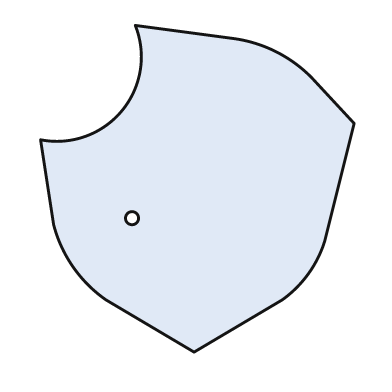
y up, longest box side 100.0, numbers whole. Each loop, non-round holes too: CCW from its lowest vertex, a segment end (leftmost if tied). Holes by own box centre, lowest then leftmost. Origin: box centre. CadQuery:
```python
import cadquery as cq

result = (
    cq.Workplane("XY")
    .moveTo(-1.0, -50.0)
    .lineTo(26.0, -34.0)
    .threePointArc((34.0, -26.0), (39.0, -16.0))
    .lineTo(48.0, 20.0)
    .lineTo(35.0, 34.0)
    .threePointArc((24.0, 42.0), (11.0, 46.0))
    .lineTo(-19.0, 50.0)
    .threePointArc((-23.0, 24.0), (-48.0, 15.0))
    .lineTo(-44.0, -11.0)
    .threePointArc((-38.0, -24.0), (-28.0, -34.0))
    .close()
    .moveTo(-20.0, -9.0)
    .circle(2.0)
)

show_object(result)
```